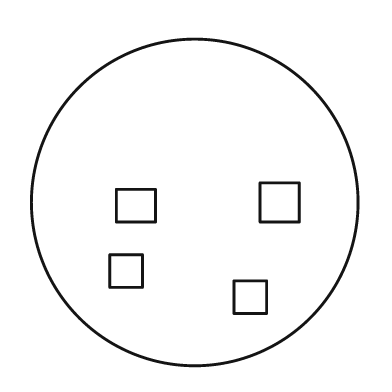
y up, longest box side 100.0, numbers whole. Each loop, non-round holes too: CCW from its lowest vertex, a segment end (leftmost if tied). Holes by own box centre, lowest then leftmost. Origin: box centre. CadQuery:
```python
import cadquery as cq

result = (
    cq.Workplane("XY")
    .moveTo(0.0, 0.0)
    .circle(50.0)
    .moveTo(12.0, -34.0)
    .lineTo(22.0, -34.0)
    .lineTo(22.0, -24.0)
    .lineTo(12.0, -24.0)
    .close()
    .moveTo(-26.0, -26.0)
    .lineTo(-16.0, -26.0)
    .lineTo(-16.0, -16.0)
    .lineTo(-26.0, -16.0)
    .close()
    .moveTo(-24.0, -6.0)
    .lineTo(-12.0, -6.0)
    .lineTo(-12.0, 4.0)
    .lineTo(-24.0, 4.0)
    .close()
    .moveTo(20.0, -6.0)
    .lineTo(32.0, -6.0)
    .lineTo(32.0, 6.0)
    .lineTo(20.0, 6.0)
    .close()
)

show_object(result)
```